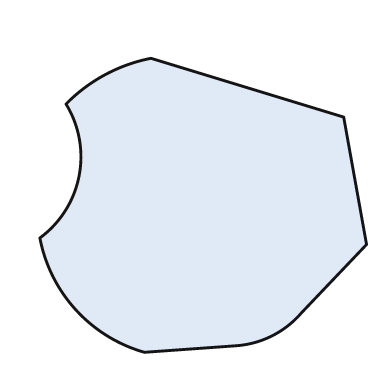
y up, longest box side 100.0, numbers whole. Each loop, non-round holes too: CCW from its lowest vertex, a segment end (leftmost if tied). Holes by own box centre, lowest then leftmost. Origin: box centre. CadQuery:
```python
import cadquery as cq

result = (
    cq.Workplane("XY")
    .moveTo(-18.0, -45.0)
    .lineTo(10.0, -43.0)
    .threePointArc((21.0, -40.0), (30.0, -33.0))
    .lineTo(50.0, -12.0)
    .lineTo(43.0, 27.0)
    .lineTo(-16.0, 45.0)
    .threePointArc((-30.0, 40.0), (-42.0, 31.0))
    .threePointArc((-38.0, 9.0), (-50.0, -10.0))
    .threePointArc((-39.0, -32.0), (-18.0, -45.0))
    .close()
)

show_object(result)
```